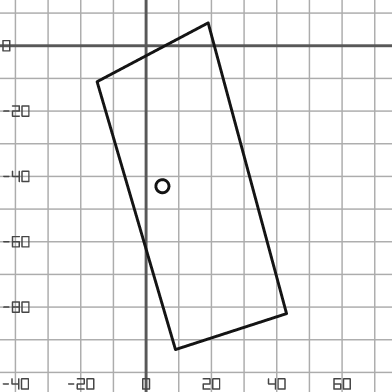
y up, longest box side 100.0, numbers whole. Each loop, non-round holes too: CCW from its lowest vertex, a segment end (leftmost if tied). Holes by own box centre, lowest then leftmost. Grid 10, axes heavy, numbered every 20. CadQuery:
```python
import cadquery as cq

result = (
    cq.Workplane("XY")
    .moveTo(9.0, -93.0)
    .lineTo(43.0, -82.0)
    .lineTo(19.0, 7.0)
    .lineTo(-15.0, -11.0)
    .close()
    .moveTo(5.0, -43.0)
    .circle(2.0)
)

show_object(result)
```